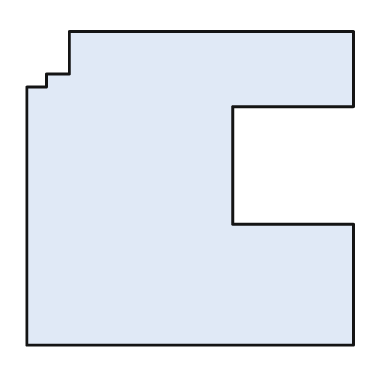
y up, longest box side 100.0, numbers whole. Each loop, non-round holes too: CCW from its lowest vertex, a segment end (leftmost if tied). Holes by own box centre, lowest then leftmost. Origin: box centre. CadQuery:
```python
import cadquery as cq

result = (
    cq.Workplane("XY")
    .moveTo(-50.0, -48.0)
    .lineTo(50.0, -48.0)
    .lineTo(50.0, -11.0)
    .lineTo(13.0, -11.0)
    .lineTo(13.0, 25.0)
    .lineTo(50.0, 25.0)
    .lineTo(50.0, 48.0)
    .lineTo(-37.0, 48.0)
    .lineTo(-37.0, 35.0)
    .lineTo(-44.0, 35.0)
    .lineTo(-44.0, 31.0)
    .lineTo(-50.0, 31.0)
    .close()
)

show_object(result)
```